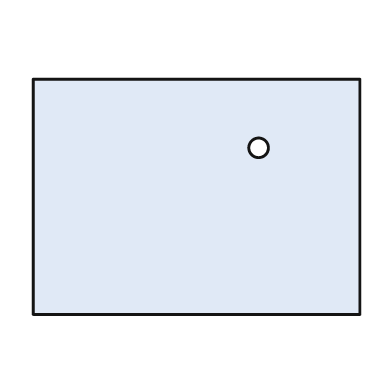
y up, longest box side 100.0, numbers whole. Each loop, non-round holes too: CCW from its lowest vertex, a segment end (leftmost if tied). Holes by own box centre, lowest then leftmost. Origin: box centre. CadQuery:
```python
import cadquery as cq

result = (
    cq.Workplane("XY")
    .moveTo(-50.0, -36.0)
    .lineTo(50.0, -36.0)
    .lineTo(50.0, 36.0)
    .lineTo(-50.0, 36.0)
    .close()
    .moveTo(19.0, 15.0)
    .circle(3.0)
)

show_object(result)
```